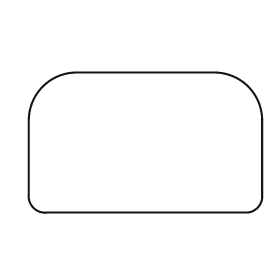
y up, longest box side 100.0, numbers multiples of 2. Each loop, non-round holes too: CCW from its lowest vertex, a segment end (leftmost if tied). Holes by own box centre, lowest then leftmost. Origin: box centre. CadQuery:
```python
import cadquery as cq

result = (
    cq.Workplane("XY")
    .moveTo(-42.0, -30.0)
    .lineTo(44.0, -30.0)
    .threePointArc((48.0, -28.0), (50.0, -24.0))
    .lineTo(50.0, 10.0)
    .threePointArc((44.0, 24.0), (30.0, 30.0))
    .lineTo(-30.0, 30.0)
    .threePointArc((-44.0, 24.0), (-50.0, 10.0))
    .lineTo(-50.0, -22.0)
    .threePointArc((-48.0, -28.0), (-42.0, -30.0))
    .close()
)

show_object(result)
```